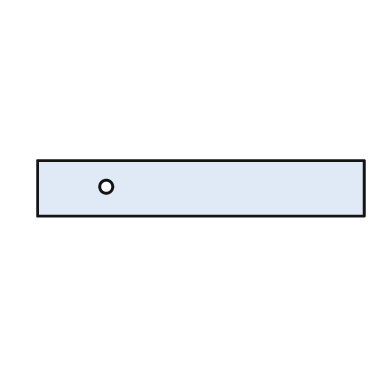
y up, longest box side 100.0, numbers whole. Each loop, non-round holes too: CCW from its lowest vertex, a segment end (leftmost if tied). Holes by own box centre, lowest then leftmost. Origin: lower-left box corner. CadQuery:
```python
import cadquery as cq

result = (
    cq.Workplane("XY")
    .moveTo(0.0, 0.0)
    .lineTo(100.0, 0.0)
    .lineTo(100.0, 17.0)
    .lineTo(0.0, 17.0)
    .close()
    .moveTo(21.0, 9.0)
    .circle(2.0)
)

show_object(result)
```